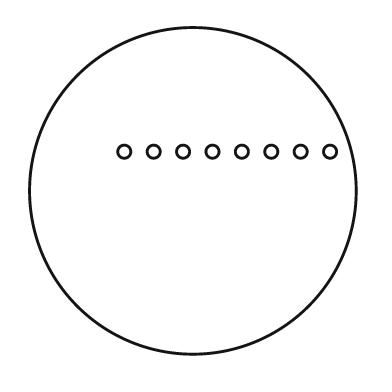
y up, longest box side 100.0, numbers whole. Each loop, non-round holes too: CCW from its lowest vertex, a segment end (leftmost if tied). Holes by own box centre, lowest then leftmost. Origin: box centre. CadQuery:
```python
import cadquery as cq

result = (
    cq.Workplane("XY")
    .moveTo(0.0, 0.0)
    .circle(50.0)
    .moveTo(-21.0, 12.0)
    .circle(2.0)
    .moveTo(-12.0, 12.0)
    .circle(2.0)
    .moveTo(-3.0, 12.0)
    .circle(2.0)
    .moveTo(6.0, 12.0)
    .circle(2.0)
    .moveTo(15.0, 12.0)
    .circle(2.0)
    .moveTo(24.0, 12.0)
    .circle(2.0)
    .moveTo(33.0, 12.0)
    .circle(2.0)
    .moveTo(42.0, 12.0)
    .circle(2.0)
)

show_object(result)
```